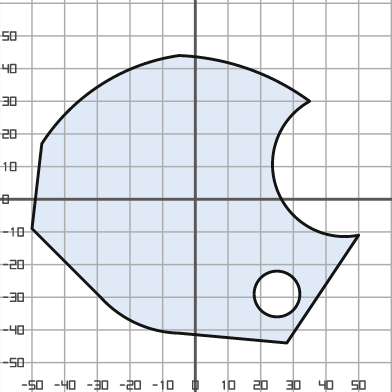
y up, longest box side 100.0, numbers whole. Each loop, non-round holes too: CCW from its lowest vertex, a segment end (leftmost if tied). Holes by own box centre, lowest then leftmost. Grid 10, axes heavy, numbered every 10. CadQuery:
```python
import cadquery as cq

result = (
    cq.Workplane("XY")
    .moveTo(28.0, -44.0)
    .lineTo(50.0, -11.0)
    .threePointArc((25.0, 3.0), (35.0, 30.0))
    .threePointArc((16.0, 40.0), (-5.0, 44.0))
    .threePointArc((-29.0, 35.0), (-47.0, 17.0))
    .lineTo(-50.0, -9.0)
    .lineTo(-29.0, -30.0)
    .threePointArc((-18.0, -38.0), (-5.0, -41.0))
    .close()
    .moveTo(25.0, -29.0)
    .circle(7.0)
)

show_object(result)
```